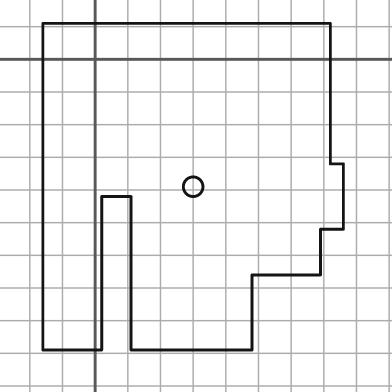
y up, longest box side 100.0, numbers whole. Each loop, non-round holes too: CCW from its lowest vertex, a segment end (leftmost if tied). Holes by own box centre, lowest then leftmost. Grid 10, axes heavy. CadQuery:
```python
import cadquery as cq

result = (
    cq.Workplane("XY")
    .moveTo(-16.0, -89.0)
    .lineTo(2.0, -89.0)
    .lineTo(2.0, -42.0)
    .lineTo(11.0, -42.0)
    .lineTo(11.0, -89.0)
    .lineTo(48.0, -89.0)
    .lineTo(48.0, -66.0)
    .lineTo(69.0, -66.0)
    .lineTo(69.0, -52.0)
    .lineTo(76.0, -52.0)
    .lineTo(76.0, -32.0)
    .lineTo(72.0, -32.0)
    .lineTo(72.0, 11.0)
    .lineTo(-16.0, 11.0)
    .close()
    .moveTo(30.0, -39.0)
    .circle(3.0)
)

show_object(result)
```